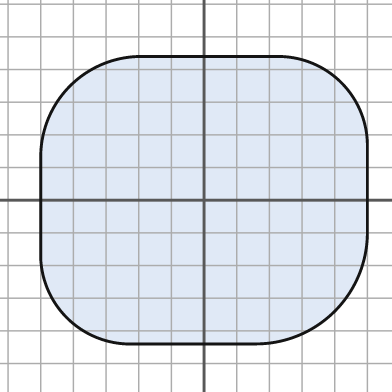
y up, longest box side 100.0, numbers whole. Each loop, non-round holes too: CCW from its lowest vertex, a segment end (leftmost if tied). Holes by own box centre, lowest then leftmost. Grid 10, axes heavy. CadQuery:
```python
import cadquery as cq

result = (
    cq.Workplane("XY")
    .moveTo(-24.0, -44.0)
    .lineTo(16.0, -44.0)
    .threePointArc((40.0, -34.0), (50.0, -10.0))
    .lineTo(50.0, 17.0)
    .threePointArc((42.0, 36.0), (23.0, 44.0))
    .lineTo(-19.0, 44.0)
    .threePointArc((-41.0, 35.0), (-50.0, 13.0))
    .lineTo(-50.0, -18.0)
    .threePointArc((-42.0, -36.0), (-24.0, -44.0))
    .close()
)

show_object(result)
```